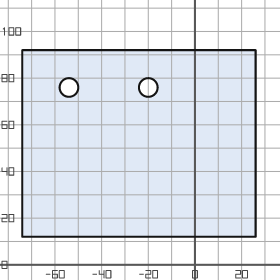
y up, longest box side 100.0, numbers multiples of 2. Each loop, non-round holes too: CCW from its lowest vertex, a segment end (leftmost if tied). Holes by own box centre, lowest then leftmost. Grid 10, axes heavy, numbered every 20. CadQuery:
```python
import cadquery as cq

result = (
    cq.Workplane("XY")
    .moveTo(-74.0, 12.0)
    .lineTo(26.0, 12.0)
    .lineTo(26.0, 92.0)
    .lineTo(-74.0, 92.0)
    .close()
    .moveTo(-54.0, 76.0)
    .circle(4.0)
    .moveTo(-20.0, 76.0)
    .circle(4.0)
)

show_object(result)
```